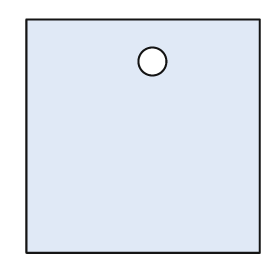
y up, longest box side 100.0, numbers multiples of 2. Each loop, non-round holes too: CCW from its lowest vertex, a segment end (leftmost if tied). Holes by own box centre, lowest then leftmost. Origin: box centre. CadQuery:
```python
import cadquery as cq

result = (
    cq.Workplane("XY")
    .moveTo(-50.0, -50.0)
    .lineTo(50.0, -50.0)
    .lineTo(50.0, 50.0)
    .lineTo(-50.0, 50.0)
    .close()
    .moveTo(4.0, 32.0)
    .circle(6.0)
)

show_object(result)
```